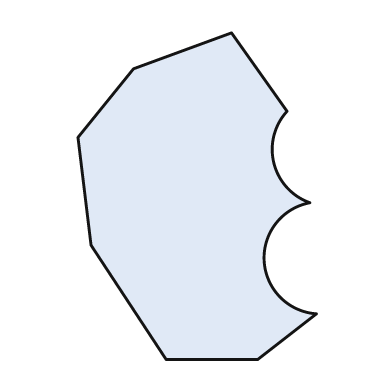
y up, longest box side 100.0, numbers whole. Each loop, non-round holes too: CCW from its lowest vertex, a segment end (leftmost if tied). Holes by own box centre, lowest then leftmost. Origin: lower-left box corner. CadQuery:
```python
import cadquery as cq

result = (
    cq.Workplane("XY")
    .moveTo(27.0, 0.0)
    .lineTo(55.0, 0.0)
    .lineTo(73.0, 14.0)
    .threePointArc((57.0, 30.0), (71.0, 48.0))
    .threePointArc((60.0, 60.0), (64.0, 76.0))
    .lineTo(47.0, 100.0)
    .lineTo(17.0, 89.0)
    .lineTo(0.0, 68.0)
    .lineTo(4.0, 35.0)
    .close()
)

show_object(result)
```